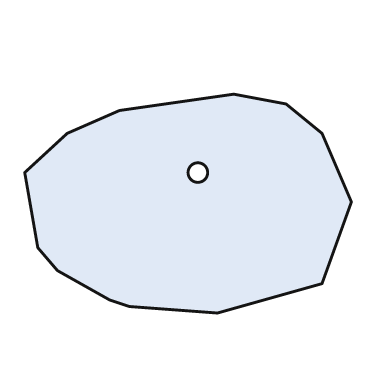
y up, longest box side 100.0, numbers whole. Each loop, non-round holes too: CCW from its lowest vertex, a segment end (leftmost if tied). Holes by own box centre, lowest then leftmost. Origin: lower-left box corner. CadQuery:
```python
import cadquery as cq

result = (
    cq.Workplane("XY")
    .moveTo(59.0, 0.0)
    .lineTo(91.0, 9.0)
    .lineTo(100.0, 34.0)
    .lineTo(91.0, 55.0)
    .lineTo(80.0, 64.0)
    .lineTo(64.0, 67.0)
    .lineTo(29.0, 62.0)
    .lineTo(13.0, 55.0)
    .lineTo(0.0, 43.0)
    .lineTo(4.0, 20.0)
    .lineTo(10.0, 13.0)
    .lineTo(26.0, 4.0)
    .lineTo(32.0, 2.0)
    .close()
    .moveTo(53.0, 43.0)
    .circle(3.0)
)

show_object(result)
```